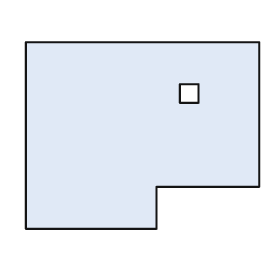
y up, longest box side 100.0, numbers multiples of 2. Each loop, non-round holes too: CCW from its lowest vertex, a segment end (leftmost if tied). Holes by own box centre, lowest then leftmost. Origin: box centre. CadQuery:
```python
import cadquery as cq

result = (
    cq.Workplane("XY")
    .moveTo(-50.0, -40.0)
    .lineTo(6.0, -40.0)
    .lineTo(6.0, -22.0)
    .lineTo(50.0, -22.0)
    .lineTo(50.0, 40.0)
    .lineTo(-50.0, 40.0)
    .close()
    .moveTo(16.0, 14.0)
    .lineTo(24.0, 14.0)
    .lineTo(24.0, 22.0)
    .lineTo(16.0, 22.0)
    .close()
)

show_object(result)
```